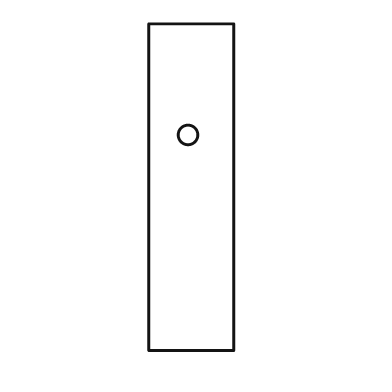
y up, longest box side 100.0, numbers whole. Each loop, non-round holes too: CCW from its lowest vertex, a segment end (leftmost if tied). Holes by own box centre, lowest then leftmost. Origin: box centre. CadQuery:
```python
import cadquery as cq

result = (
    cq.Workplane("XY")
    .moveTo(-13.0, -50.0)
    .lineTo(13.0, -50.0)
    .lineTo(13.0, 50.0)
    .lineTo(-13.0, 50.0)
    .close()
    .moveTo(-1.0, 16.0)
    .circle(3.0)
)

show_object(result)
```